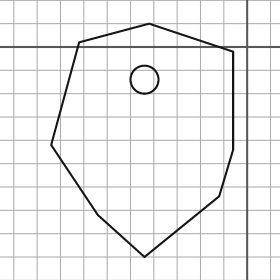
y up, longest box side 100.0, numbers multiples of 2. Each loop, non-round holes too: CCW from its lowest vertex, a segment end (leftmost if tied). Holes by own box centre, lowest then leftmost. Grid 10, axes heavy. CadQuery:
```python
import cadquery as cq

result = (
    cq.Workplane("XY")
    .moveTo(-44.0, -90.0)
    .lineTo(-12.0, -64.0)
    .lineTo(-6.0, -44.0)
    .lineTo(-6.0, -2.0)
    .lineTo(-42.0, 10.0)
    .lineTo(-72.0, 2.0)
    .lineTo(-84.0, -42.0)
    .lineTo(-64.0, -72.0)
    .close()
    .moveTo(-44.0, -14.0)
    .circle(6.0)
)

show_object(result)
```